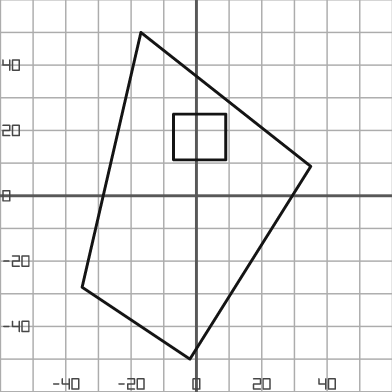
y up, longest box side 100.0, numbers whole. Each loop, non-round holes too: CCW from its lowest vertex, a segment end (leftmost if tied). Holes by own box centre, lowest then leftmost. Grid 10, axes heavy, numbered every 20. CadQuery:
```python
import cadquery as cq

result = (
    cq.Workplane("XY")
    .moveTo(-2.0, -50.0)
    .lineTo(35.0, 9.0)
    .lineTo(-17.0, 50.0)
    .lineTo(-35.0, -28.0)
    .close()
    .moveTo(-7.0, 11.0)
    .lineTo(9.0, 11.0)
    .lineTo(9.0, 25.0)
    .lineTo(-7.0, 25.0)
    .close()
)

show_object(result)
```